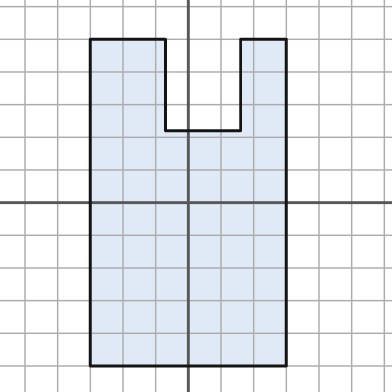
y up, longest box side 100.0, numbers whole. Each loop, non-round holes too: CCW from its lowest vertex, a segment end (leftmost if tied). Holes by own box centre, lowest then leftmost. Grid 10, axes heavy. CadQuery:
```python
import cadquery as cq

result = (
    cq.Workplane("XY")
    .moveTo(-30.0, -50.0)
    .lineTo(30.0, -50.0)
    .lineTo(30.0, 50.0)
    .lineTo(16.0, 50.0)
    .lineTo(16.0, 22.0)
    .lineTo(-7.0, 22.0)
    .lineTo(-7.0, 50.0)
    .lineTo(-30.0, 50.0)
    .close()
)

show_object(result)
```